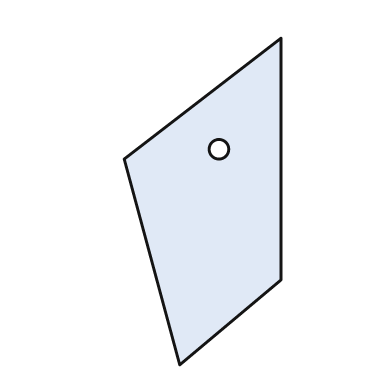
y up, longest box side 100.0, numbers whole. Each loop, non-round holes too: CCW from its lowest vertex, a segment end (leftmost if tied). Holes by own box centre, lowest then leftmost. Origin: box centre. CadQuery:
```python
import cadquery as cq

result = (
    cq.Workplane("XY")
    .moveTo(-7.0, -50.0)
    .lineTo(24.0, -24.0)
    .lineTo(24.0, 50.0)
    .lineTo(-24.0, 13.0)
    .close()
    .moveTo(5.0, 16.0)
    .circle(3.0)
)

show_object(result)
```